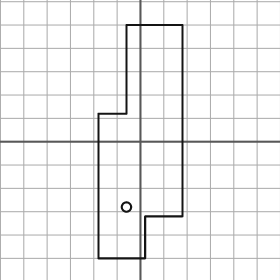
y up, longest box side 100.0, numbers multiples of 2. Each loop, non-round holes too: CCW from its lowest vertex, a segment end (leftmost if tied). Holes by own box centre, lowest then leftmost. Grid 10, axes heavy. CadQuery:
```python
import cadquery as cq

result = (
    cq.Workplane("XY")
    .moveTo(-18.0, -50.0)
    .lineTo(2.0, -50.0)
    .lineTo(2.0, -32.0)
    .lineTo(18.0, -32.0)
    .lineTo(18.0, 50.0)
    .lineTo(-6.0, 50.0)
    .lineTo(-6.0, 12.0)
    .lineTo(-18.0, 12.0)
    .close()
    .moveTo(-6.0, -28.0)
    .circle(2.0)
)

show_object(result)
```